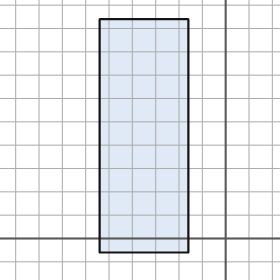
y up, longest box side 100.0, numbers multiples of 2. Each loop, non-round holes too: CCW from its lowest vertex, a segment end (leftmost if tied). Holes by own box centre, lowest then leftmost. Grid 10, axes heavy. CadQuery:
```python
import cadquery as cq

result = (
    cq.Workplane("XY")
    .moveTo(-54.0, -6.0)
    .lineTo(-16.0, -6.0)
    .lineTo(-16.0, 94.0)
    .lineTo(-54.0, 94.0)
    .close()
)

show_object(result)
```